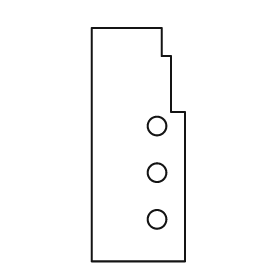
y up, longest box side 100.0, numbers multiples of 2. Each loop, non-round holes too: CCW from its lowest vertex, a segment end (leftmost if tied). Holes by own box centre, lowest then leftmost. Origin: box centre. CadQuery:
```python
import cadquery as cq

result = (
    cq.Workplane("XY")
    .moveTo(-20.0, -50.0)
    .lineTo(20.0, -50.0)
    .lineTo(20.0, 14.0)
    .lineTo(14.0, 14.0)
    .lineTo(14.0, 38.0)
    .lineTo(10.0, 38.0)
    .lineTo(10.0, 50.0)
    .lineTo(-20.0, 50.0)
    .close()
    .moveTo(8.0, -32.0)
    .circle(4.0)
    .moveTo(8.0, -12.0)
    .circle(4.0)
    .moveTo(8.0, 8.0)
    .circle(4.0)
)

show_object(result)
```